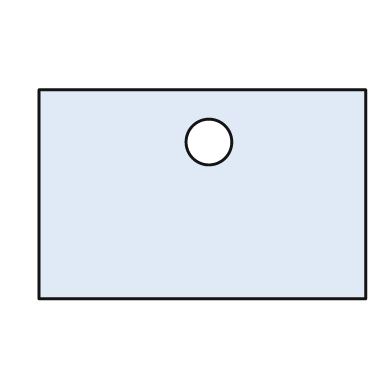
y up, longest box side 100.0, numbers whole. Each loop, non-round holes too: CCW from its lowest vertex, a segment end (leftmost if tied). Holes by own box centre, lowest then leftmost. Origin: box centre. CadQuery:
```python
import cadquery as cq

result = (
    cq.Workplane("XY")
    .moveTo(-50.0, -32.0)
    .lineTo(50.0, -32.0)
    .lineTo(50.0, 32.0)
    .lineTo(-50.0, 32.0)
    .close()
    .moveTo(2.0, 16.0)
    .circle(7.0)
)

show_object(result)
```